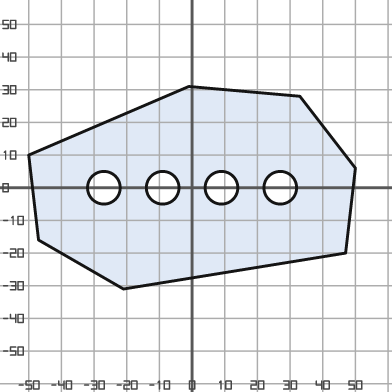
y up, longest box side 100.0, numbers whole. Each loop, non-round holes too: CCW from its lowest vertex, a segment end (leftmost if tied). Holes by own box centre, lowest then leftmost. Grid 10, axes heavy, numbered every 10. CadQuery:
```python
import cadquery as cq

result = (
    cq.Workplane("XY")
    .moveTo(-21.0, -31.0)
    .lineTo(47.0, -20.0)
    .lineTo(50.0, 6.0)
    .lineTo(33.0, 28.0)
    .lineTo(-1.0, 31.0)
    .lineTo(-50.0, 10.0)
    .lineTo(-47.0, -16.0)
    .close()
    .moveTo(-27.0, 0.0)
    .circle(5.0)
    .moveTo(-9.0, 0.0)
    .circle(5.0)
    .moveTo(9.0, 0.0)
    .circle(5.0)
    .moveTo(27.0, 0.0)
    .circle(5.0)
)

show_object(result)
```